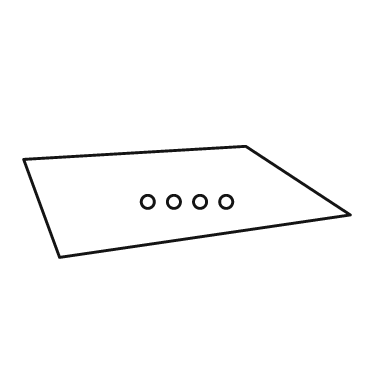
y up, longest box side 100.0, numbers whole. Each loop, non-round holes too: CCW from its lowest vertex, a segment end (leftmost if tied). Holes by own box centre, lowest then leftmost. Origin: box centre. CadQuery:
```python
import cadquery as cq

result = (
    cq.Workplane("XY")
    .moveTo(-39.0, -17.0)
    .lineTo(50.0, -4.0)
    .lineTo(18.0, 17.0)
    .lineTo(-50.0, 13.0)
    .close()
    .moveTo(-12.0, 0.0)
    .circle(2.0)
    .moveTo(-4.0, 0.0)
    .circle(2.0)
    .moveTo(4.0, 0.0)
    .circle(2.0)
    .moveTo(12.0, 0.0)
    .circle(2.0)
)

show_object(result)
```